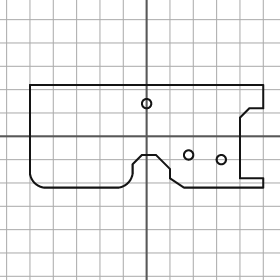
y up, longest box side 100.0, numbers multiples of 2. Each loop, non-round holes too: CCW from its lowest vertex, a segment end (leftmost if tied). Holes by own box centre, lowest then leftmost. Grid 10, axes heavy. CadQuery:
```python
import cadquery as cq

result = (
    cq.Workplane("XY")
    .moveTo(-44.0, -22.0)
    .lineTo(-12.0, -22.0)
    .threePointArc((-8.0, -20.0), (-6.0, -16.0))
    .lineTo(-6.0, -12.0)
    .lineTo(-2.0, -8.0)
    .lineTo(4.0, -8.0)
    .lineTo(10.0, -14.0)
    .lineTo(10.0, -18.0)
    .lineTo(16.0, -22.0)
    .lineTo(50.0, -22.0)
    .lineTo(50.0, -18.0)
    .lineTo(40.0, -18.0)
    .lineTo(40.0, 8.0)
    .lineTo(44.0, 12.0)
    .lineTo(50.0, 12.0)
    .lineTo(50.0, 22.0)
    .lineTo(-50.0, 22.0)
    .lineTo(-50.0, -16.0)
    .threePointArc((-48.0, -20.0), (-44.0, -22.0))
    .close()
    .moveTo(32.0, -10.0)
    .circle(2.0)
    .moveTo(18.0, -8.0)
    .circle(2.0)
    .moveTo(0.0, 14.0)
    .circle(2.0)
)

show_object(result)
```